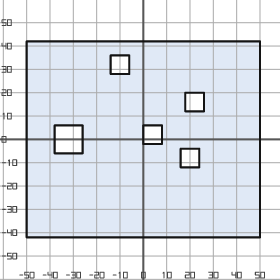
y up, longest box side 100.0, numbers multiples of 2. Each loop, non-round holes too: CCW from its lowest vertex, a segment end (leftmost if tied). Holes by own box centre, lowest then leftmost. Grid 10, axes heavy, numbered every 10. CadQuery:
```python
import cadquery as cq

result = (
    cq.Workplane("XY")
    .moveTo(-50.0, -42.0)
    .lineTo(50.0, -42.0)
    .lineTo(50.0, 42.0)
    .lineTo(-50.0, 42.0)
    .close()
    .moveTo(16.0, -12.0)
    .lineTo(24.0, -12.0)
    .lineTo(24.0, -4.0)
    .lineTo(16.0, -4.0)
    .close()
    .moveTo(-38.0, -6.0)
    .lineTo(-26.0, -6.0)
    .lineTo(-26.0, 6.0)
    .lineTo(-38.0, 6.0)
    .close()
    .moveTo(0.0, -2.0)
    .lineTo(8.0, -2.0)
    .lineTo(8.0, 6.0)
    .lineTo(0.0, 6.0)
    .close()
    .moveTo(18.0, 12.0)
    .lineTo(26.0, 12.0)
    .lineTo(26.0, 20.0)
    .lineTo(18.0, 20.0)
    .close()
    .moveTo(-14.0, 28.0)
    .lineTo(-6.0, 28.0)
    .lineTo(-6.0, 36.0)
    .lineTo(-14.0, 36.0)
    .close()
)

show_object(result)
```